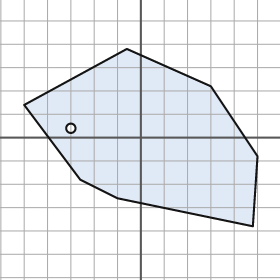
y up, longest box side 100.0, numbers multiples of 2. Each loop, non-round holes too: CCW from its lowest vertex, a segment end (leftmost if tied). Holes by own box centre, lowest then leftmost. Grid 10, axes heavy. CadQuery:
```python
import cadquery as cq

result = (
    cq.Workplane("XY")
    .moveTo(48.0, -38.0)
    .lineTo(50.0, -8.0)
    .lineTo(30.0, 22.0)
    .lineTo(-6.0, 38.0)
    .lineTo(-50.0, 14.0)
    .lineTo(-26.0, -18.0)
    .lineTo(-10.0, -26.0)
    .close()
    .moveTo(-30.0, 4.0)
    .circle(2.0)
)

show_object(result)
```